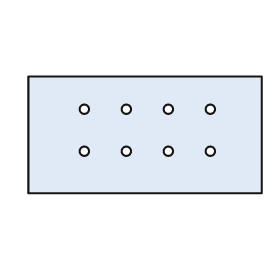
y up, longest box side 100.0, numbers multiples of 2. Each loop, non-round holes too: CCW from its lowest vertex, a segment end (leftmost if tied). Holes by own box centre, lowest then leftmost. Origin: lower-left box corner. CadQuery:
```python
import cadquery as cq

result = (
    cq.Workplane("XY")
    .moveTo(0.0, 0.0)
    .lineTo(100.0, 0.0)
    .lineTo(100.0, 50.0)
    .lineTo(0.0, 50.0)
    .close()
    .moveTo(24.0, 18.0)
    .circle(2.0)
    .moveTo(42.0, 18.0)
    .circle(2.0)
    .moveTo(60.0, 18.0)
    .circle(2.0)
    .moveTo(78.0, 18.0)
    .circle(2.0)
    .moveTo(24.0, 36.0)
    .circle(2.0)
    .moveTo(42.0, 36.0)
    .circle(2.0)
    .moveTo(60.0, 36.0)
    .circle(2.0)
    .moveTo(78.0, 36.0)
    .circle(2.0)
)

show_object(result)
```